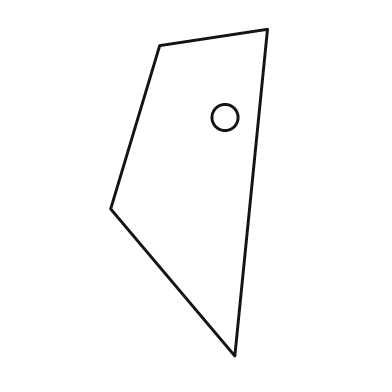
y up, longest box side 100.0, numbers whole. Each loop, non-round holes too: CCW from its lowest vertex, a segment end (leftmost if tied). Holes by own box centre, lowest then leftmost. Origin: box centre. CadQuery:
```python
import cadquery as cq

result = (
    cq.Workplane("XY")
    .moveTo(14.0, -50.0)
    .lineTo(24.0, 50.0)
    .lineTo(-9.0, 45.0)
    .lineTo(-24.0, -5.0)
    .close()
    .moveTo(11.0, 23.0)
    .circle(4.0)
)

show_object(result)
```